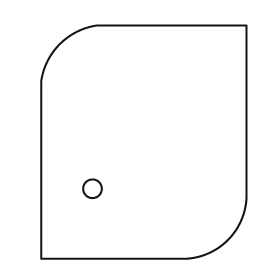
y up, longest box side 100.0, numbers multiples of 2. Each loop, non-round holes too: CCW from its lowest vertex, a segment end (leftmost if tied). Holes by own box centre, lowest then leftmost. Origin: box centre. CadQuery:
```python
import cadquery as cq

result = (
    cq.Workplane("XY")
    .moveTo(-44.0, -50.0)
    .lineTo(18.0, -50.0)
    .threePointArc((36.0, -42.0), (44.0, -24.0))
    .lineTo(44.0, 50.0)
    .lineTo(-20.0, 50.0)
    .threePointArc((-36.0, 42.0), (-44.0, 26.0))
    .close()
    .moveTo(-22.0, -20.0)
    .circle(4.0)
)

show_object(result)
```